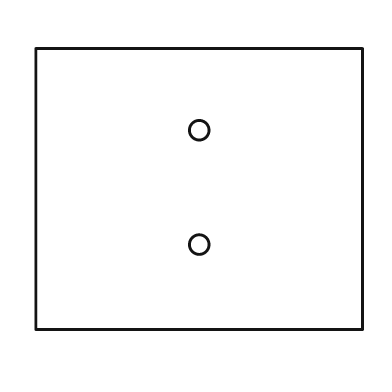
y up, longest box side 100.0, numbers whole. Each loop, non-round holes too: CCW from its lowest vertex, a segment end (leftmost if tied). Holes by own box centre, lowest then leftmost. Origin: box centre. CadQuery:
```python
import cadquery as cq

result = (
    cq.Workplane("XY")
    .moveTo(-50.0, -43.0)
    .lineTo(50.0, -43.0)
    .lineTo(50.0, 43.0)
    .lineTo(-50.0, 43.0)
    .close()
    .moveTo(0.0, -17.0)
    .circle(3.0)
    .moveTo(0.0, 18.0)
    .circle(3.0)
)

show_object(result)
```